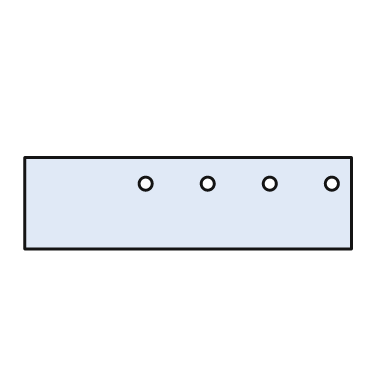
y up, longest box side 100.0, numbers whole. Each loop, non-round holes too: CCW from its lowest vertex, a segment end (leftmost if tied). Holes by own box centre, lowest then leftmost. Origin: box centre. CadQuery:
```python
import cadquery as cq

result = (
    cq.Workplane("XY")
    .moveTo(-50.0, -14.0)
    .lineTo(50.0, -14.0)
    .lineTo(50.0, 14.0)
    .lineTo(-50.0, 14.0)
    .close()
    .moveTo(-13.0, 6.0)
    .circle(2.0)
    .moveTo(6.0, 6.0)
    .circle(2.0)
    .moveTo(25.0, 6.0)
    .circle(2.0)
    .moveTo(44.0, 6.0)
    .circle(2.0)
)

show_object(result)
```